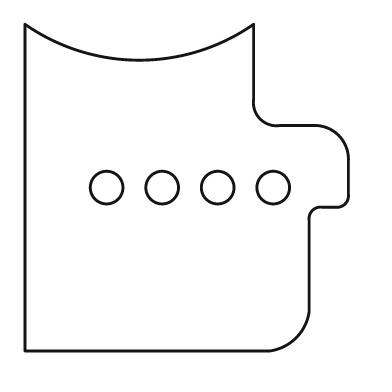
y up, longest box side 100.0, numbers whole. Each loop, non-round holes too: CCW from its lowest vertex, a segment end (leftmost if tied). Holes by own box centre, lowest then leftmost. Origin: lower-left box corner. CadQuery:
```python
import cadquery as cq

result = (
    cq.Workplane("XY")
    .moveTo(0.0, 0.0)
    .lineTo(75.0, 0.0)
    .threePointArc((83.0, 4.0), (87.0, 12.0))
    .lineTo(87.0, 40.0)
    .threePointArc((88.0, 43.0), (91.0, 44.0))
    .lineTo(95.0, 44.0)
    .threePointArc((98.0, 45.0), (99.0, 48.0))
    .lineTo(99.0, 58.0)
    .threePointArc((96.0, 66.0), (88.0, 69.0))
    .lineTo(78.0, 69.0)
    .threePointArc((72.0, 71.0), (70.0, 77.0))
    .lineTo(70.0, 100.0)
    .threePointArc((35.0, 89.0), (0.0, 100.0))
    .close()
    .moveTo(25.0, 50.0)
    .circle(5.0)
    .moveTo(42.0, 50.0)
    .circle(5.0)
    .moveTo(59.0, 50.0)
    .circle(5.0)
    .moveTo(76.0, 50.0)
    .circle(5.0)
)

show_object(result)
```